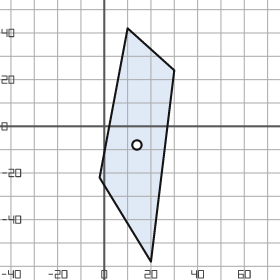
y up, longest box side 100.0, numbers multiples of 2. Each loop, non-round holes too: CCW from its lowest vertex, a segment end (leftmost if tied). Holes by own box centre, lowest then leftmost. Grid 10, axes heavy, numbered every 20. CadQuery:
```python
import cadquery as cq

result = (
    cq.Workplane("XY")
    .moveTo(20.0, -58.0)
    .lineTo(30.0, 24.0)
    .lineTo(10.0, 42.0)
    .lineTo(-2.0, -22.0)
    .close()
    .moveTo(14.0, -8.0)
    .circle(2.0)
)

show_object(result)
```